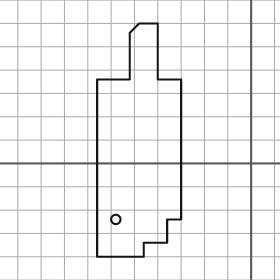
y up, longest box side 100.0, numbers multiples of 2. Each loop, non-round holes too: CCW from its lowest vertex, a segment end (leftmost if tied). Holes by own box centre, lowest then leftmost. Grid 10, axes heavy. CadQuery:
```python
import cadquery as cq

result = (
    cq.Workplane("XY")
    .moveTo(-66.0, -40.0)
    .lineTo(-46.0, -40.0)
    .lineTo(-46.0, -34.0)
    .lineTo(-36.0, -34.0)
    .lineTo(-36.0, -24.0)
    .lineTo(-30.0, -24.0)
    .lineTo(-30.0, 36.0)
    .lineTo(-40.0, 36.0)
    .lineTo(-40.0, 60.0)
    .lineTo(-48.0, 60.0)
    .lineTo(-52.0, 56.0)
    .lineTo(-52.0, 36.0)
    .lineTo(-66.0, 36.0)
    .close()
    .moveTo(-58.0, -24.0)
    .circle(2.0)
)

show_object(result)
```